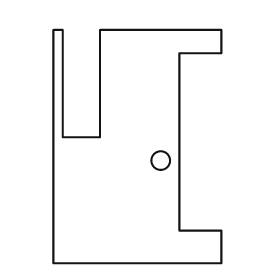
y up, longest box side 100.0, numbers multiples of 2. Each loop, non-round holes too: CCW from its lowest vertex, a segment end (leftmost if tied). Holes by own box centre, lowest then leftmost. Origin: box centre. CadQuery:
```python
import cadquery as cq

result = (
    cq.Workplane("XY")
    .moveTo(-36.0, -50.0)
    .lineTo(36.0, -50.0)
    .lineTo(36.0, -36.0)
    .lineTo(18.0, -36.0)
    .lineTo(18.0, 40.0)
    .lineTo(36.0, 40.0)
    .lineTo(36.0, 50.0)
    .lineTo(-16.0, 50.0)
    .lineTo(-16.0, 4.0)
    .lineTo(-32.0, 4.0)
    .lineTo(-32.0, 50.0)
    .lineTo(-36.0, 50.0)
    .close()
    .moveTo(10.0, -6.0)
    .circle(4.0)
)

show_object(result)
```